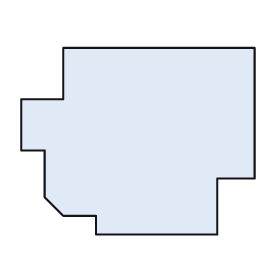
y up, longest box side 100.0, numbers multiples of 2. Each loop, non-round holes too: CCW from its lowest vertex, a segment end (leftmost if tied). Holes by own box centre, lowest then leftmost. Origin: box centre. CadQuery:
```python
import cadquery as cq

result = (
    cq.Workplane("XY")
    .moveTo(-18.0, -40.0)
    .lineTo(34.0, -40.0)
    .lineTo(34.0, -16.0)
    .lineTo(50.0, -16.0)
    .lineTo(50.0, 40.0)
    .lineTo(-32.0, 40.0)
    .lineTo(-32.0, 18.0)
    .lineTo(-50.0, 18.0)
    .lineTo(-50.0, -4.0)
    .lineTo(-40.0, -4.0)
    .lineTo(-40.0, -24.0)
    .lineTo(-32.0, -32.0)
    .lineTo(-18.0, -32.0)
    .close()
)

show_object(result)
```